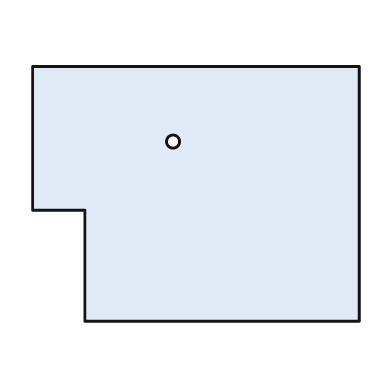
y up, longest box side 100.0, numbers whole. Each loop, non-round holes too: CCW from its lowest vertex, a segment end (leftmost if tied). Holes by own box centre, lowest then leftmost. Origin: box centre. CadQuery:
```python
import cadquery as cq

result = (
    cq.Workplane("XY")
    .moveTo(-34.0, -39.0)
    .lineTo(50.0, -39.0)
    .lineTo(50.0, 39.0)
    .lineTo(-50.0, 39.0)
    .lineTo(-50.0, -5.0)
    .lineTo(-34.0, -5.0)
    .close()
    .moveTo(-7.0, 16.0)
    .circle(2.0)
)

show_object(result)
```